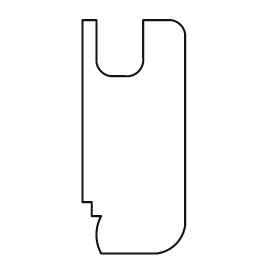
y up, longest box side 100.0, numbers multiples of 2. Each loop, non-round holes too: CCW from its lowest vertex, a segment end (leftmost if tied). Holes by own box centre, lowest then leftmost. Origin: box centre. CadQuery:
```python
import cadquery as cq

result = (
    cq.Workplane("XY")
    .moveTo(-14.0, -50.0)
    .lineTo(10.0, -50.0)
    .threePointArc((18.0, -46.0), (22.0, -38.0))
    .lineTo(22.0, 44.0)
    .threePointArc((20.0, 48.0), (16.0, 50.0))
    .lineTo(4.0, 50.0)
    .lineTo(4.0, 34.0)
    .threePointArc((2.0, 28.0), (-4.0, 26.0))
    .lineTo(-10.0, 26.0)
    .threePointArc((-14.0, 28.0), (-16.0, 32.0))
    .lineTo(-16.0, 50.0)
    .lineTo(-22.0, 50.0)
    .lineTo(-22.0, -28.0)
    .lineTo(-18.0, -28.0)
    .lineTo(-18.0, -34.0)
    .lineTo(-14.0, -34.0)
    .threePointArc((-16.0, -42.0), (-14.0, -50.0))
    .close()
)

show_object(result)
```